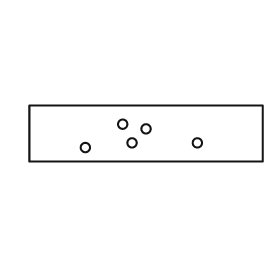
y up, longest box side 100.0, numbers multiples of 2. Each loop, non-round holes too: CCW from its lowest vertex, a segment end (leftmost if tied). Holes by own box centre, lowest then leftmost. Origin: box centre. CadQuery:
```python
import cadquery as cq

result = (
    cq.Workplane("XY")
    .moveTo(-50.0, -12.0)
    .lineTo(50.0, -12.0)
    .lineTo(50.0, 12.0)
    .lineTo(-50.0, 12.0)
    .close()
    .moveTo(-26.0, -6.0)
    .circle(2.0)
    .moveTo(-6.0, -4.0)
    .circle(2.0)
    .moveTo(22.0, -4.0)
    .circle(2.0)
    .moveTo(0.0, 2.0)
    .circle(2.0)
    .moveTo(-10.0, 4.0)
    .circle(2.0)
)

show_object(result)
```